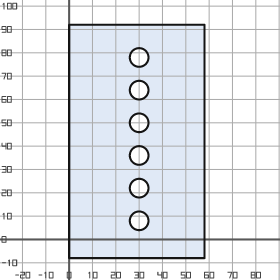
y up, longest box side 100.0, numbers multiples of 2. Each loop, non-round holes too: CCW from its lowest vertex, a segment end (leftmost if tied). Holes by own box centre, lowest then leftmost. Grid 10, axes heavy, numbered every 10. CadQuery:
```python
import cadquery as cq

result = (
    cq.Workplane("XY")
    .moveTo(0.0, -8.0)
    .lineTo(58.0, -8.0)
    .lineTo(58.0, 92.0)
    .lineTo(0.0, 92.0)
    .close()
    .moveTo(30.0, 8.0)
    .circle(4.0)
    .moveTo(30.0, 22.0)
    .circle(4.0)
    .moveTo(30.0, 36.0)
    .circle(4.0)
    .moveTo(30.0, 50.0)
    .circle(4.0)
    .moveTo(30.0, 64.0)
    .circle(4.0)
    .moveTo(30.0, 78.0)
    .circle(4.0)
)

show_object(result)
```